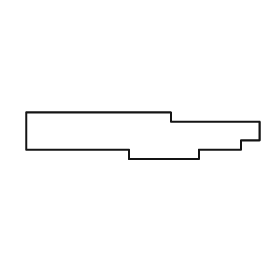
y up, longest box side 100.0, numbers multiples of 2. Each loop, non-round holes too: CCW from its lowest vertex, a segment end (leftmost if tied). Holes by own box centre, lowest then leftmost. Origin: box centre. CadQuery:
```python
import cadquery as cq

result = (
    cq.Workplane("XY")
    .moveTo(-6.0, -10.0)
    .lineTo(24.0, -10.0)
    .lineTo(24.0, -6.0)
    .lineTo(42.0, -6.0)
    .lineTo(42.0, -2.0)
    .lineTo(50.0, -2.0)
    .lineTo(50.0, 6.0)
    .lineTo(12.0, 6.0)
    .lineTo(12.0, 10.0)
    .lineTo(-50.0, 10.0)
    .lineTo(-50.0, -6.0)
    .lineTo(-6.0, -6.0)
    .close()
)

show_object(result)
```